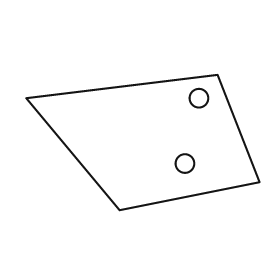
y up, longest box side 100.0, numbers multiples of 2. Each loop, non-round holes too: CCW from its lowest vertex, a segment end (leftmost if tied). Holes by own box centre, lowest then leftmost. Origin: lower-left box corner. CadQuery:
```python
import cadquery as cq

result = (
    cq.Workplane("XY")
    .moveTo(40.0, 0.0)
    .lineTo(100.0, 12.0)
    .lineTo(82.0, 58.0)
    .lineTo(0.0, 48.0)
    .close()
    .moveTo(68.0, 20.0)
    .circle(4.0)
    .moveTo(74.0, 48.0)
    .circle(4.0)
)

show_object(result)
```